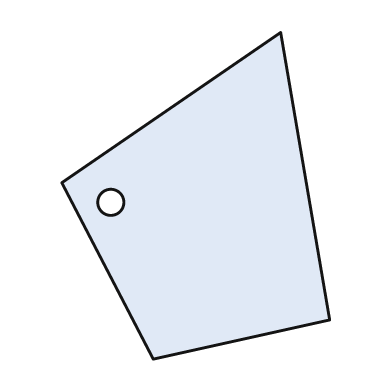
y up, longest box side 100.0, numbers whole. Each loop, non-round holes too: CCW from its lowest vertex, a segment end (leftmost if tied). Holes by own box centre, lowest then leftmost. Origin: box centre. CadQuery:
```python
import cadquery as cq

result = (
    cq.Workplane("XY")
    .moveTo(-13.0, -50.0)
    .lineTo(41.0, -38.0)
    .lineTo(26.0, 50.0)
    .lineTo(-41.0, 4.0)
    .close()
    .moveTo(-26.0, -2.0)
    .circle(4.0)
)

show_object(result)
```